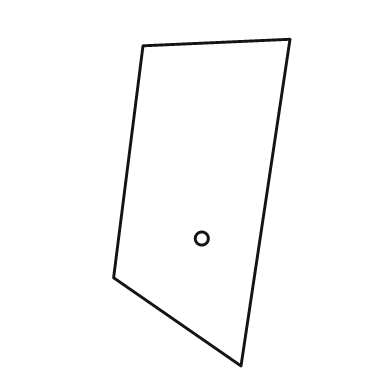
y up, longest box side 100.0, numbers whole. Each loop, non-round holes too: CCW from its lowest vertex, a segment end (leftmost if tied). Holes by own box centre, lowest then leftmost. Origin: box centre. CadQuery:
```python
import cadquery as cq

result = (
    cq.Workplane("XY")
    .moveTo(12.0, -50.0)
    .lineTo(27.0, 50.0)
    .lineTo(-18.0, 48.0)
    .lineTo(-27.0, -23.0)
    .close()
    .moveTo(0.0, -11.0)
    .circle(2.0)
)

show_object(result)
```